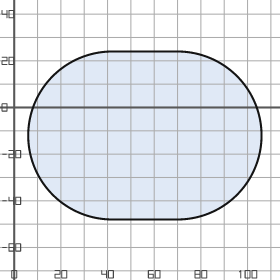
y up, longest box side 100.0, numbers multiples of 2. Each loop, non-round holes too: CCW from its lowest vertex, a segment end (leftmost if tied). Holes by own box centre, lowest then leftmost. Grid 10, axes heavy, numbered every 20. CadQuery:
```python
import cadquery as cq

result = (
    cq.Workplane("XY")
    .moveTo(42.0, -48.0)
    .lineTo(70.0, -48.0)
    .threePointArc((106.0, -12.0), (70.0, 24.0))
    .lineTo(42.0, 24.0)
    .threePointArc((6.0, -12.0), (42.0, -48.0))
    .close()
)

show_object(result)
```